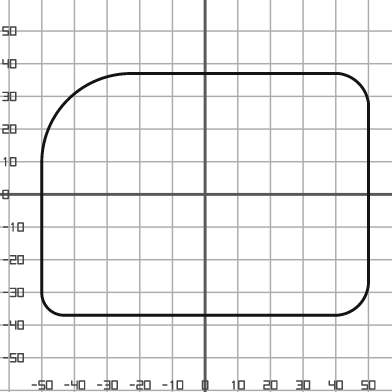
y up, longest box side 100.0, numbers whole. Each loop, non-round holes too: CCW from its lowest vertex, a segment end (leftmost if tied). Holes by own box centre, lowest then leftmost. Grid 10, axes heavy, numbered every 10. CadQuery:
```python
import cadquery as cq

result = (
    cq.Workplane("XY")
    .moveTo(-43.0, -37.0)
    .lineTo(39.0, -37.0)
    .threePointArc((47.0, -34.0), (50.0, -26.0))
    .lineTo(50.0, 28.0)
    .threePointArc((47.0, 34.0), (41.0, 37.0))
    .lineTo(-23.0, 37.0)
    .threePointArc((-42.0, 29.0), (-50.0, 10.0))
    .lineTo(-50.0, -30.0)
    .threePointArc((-48.0, -35.0), (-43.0, -37.0))
    .close()
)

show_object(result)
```